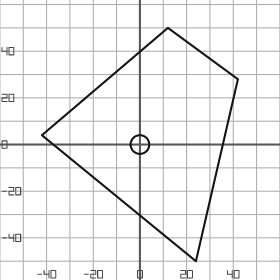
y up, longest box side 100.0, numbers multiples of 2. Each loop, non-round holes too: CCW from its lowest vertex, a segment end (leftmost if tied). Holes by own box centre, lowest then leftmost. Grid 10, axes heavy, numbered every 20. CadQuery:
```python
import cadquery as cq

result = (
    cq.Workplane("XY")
    .moveTo(24.0, -50.0)
    .lineTo(42.0, 28.0)
    .lineTo(12.0, 50.0)
    .lineTo(-42.0, 4.0)
    .close()
    .moveTo(0.0, 0.0)
    .circle(4.0)
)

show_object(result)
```